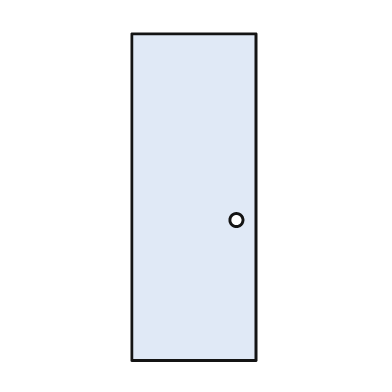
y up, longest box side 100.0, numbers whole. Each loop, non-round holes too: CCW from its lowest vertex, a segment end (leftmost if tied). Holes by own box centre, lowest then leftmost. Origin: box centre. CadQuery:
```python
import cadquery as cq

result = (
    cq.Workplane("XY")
    .moveTo(-19.0, -50.0)
    .lineTo(19.0, -50.0)
    .lineTo(19.0, 50.0)
    .lineTo(-19.0, 50.0)
    .close()
    .moveTo(13.0, -7.0)
    .circle(2.0)
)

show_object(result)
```